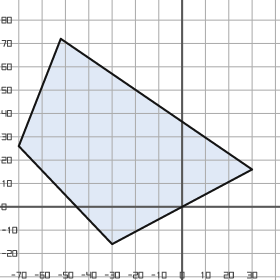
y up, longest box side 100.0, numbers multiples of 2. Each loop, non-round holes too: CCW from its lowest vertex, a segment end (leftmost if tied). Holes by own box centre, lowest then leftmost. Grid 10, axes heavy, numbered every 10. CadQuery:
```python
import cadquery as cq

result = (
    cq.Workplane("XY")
    .moveTo(-30.0, -16.0)
    .lineTo(30.0, 16.0)
    .lineTo(-52.0, 72.0)
    .lineTo(-70.0, 26.0)
    .close()
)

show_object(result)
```